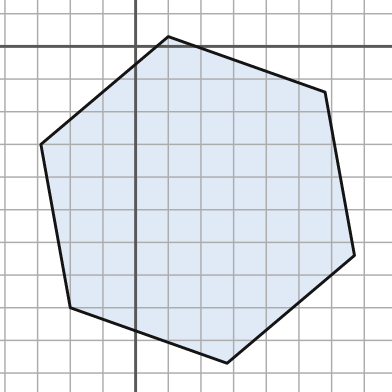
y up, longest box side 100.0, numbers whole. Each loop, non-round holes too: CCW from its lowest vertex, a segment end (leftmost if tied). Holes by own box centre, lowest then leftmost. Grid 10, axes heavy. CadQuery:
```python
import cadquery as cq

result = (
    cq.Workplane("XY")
    .moveTo(28.0, -97.0)
    .lineTo(67.0, -64.0)
    .lineTo(58.0, -14.0)
    .lineTo(10.0, 3.0)
    .lineTo(-29.0, -30.0)
    .lineTo(-20.0, -80.0)
    .close()
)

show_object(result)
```